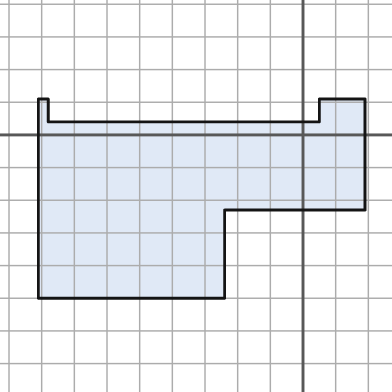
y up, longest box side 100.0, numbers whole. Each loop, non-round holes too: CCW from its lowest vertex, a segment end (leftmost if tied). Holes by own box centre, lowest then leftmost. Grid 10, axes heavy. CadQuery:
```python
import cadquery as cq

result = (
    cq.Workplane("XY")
    .moveTo(-81.0, -50.0)
    .lineTo(-24.0, -50.0)
    .lineTo(-24.0, -23.0)
    .lineTo(19.0, -23.0)
    .lineTo(19.0, 11.0)
    .lineTo(5.0, 11.0)
    .lineTo(5.0, 4.0)
    .lineTo(-78.0, 4.0)
    .lineTo(-78.0, 11.0)
    .lineTo(-81.0, 11.0)
    .close()
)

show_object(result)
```